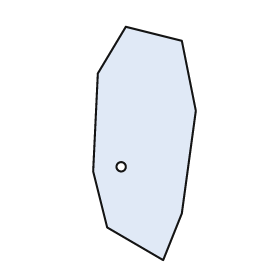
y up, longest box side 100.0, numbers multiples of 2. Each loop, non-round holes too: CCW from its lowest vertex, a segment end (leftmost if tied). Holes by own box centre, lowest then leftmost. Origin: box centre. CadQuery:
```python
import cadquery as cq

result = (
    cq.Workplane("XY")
    .moveTo(8.0, -50.0)
    .lineTo(16.0, -30.0)
    .lineTo(22.0, 14.0)
    .lineTo(16.0, 44.0)
    .lineTo(-8.0, 50.0)
    .lineTo(-20.0, 30.0)
    .lineTo(-22.0, -12.0)
    .lineTo(-16.0, -36.0)
    .close()
    .moveTo(-10.0, -10.0)
    .circle(2.0)
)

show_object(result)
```